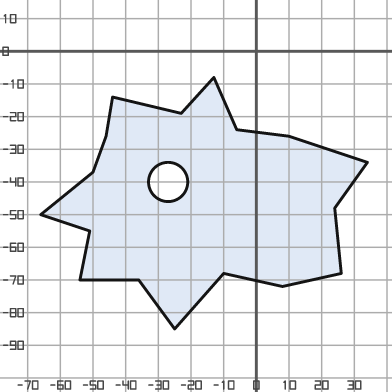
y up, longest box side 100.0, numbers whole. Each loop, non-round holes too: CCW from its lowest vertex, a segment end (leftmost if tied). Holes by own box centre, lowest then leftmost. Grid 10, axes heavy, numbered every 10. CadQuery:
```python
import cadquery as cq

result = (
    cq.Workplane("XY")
    .moveTo(-25.0, -85.0)
    .lineTo(-10.0, -68.0)
    .lineTo(8.0, -72.0)
    .lineTo(26.0, -68.0)
    .lineTo(24.0, -48.0)
    .lineTo(34.0, -34.0)
    .lineTo(10.0, -26.0)
    .lineTo(-6.0, -24.0)
    .lineTo(-13.0, -8.0)
    .lineTo(-23.0, -19.0)
    .lineTo(-44.0, -14.0)
    .lineTo(-46.0, -26.0)
    .lineTo(-50.0, -37.0)
    .lineTo(-66.0, -50.0)
    .lineTo(-51.0, -55.0)
    .lineTo(-54.0, -70.0)
    .lineTo(-36.0, -70.0)
    .close()
    .moveTo(-27.0, -40.0)
    .circle(6.0)
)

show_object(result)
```